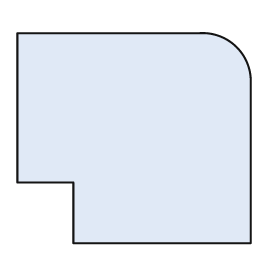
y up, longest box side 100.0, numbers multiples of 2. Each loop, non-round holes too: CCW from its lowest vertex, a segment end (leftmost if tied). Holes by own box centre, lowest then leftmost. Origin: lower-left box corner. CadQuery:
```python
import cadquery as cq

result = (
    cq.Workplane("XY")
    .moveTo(24.0, 0.0)
    .lineTo(100.0, 0.0)
    .lineTo(100.0, 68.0)
    .threePointArc((94.0, 84.0), (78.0, 90.0))
    .lineTo(0.0, 90.0)
    .lineTo(0.0, 26.0)
    .lineTo(24.0, 26.0)
    .close()
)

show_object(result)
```